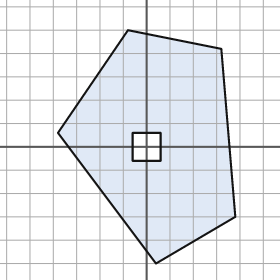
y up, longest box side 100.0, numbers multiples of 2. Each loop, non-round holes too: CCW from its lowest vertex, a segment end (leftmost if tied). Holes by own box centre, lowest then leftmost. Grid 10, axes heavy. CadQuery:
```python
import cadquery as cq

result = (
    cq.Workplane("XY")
    .moveTo(4.0, -50.0)
    .lineTo(38.0, -30.0)
    .lineTo(32.0, 42.0)
    .lineTo(-8.0, 50.0)
    .lineTo(-38.0, 6.0)
    .close()
    .moveTo(-6.0, -6.0)
    .lineTo(6.0, -6.0)
    .lineTo(6.0, 6.0)
    .lineTo(-6.0, 6.0)
    .close()
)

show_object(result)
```